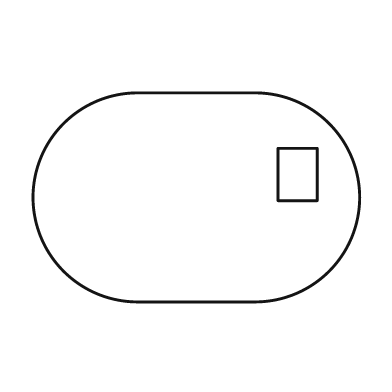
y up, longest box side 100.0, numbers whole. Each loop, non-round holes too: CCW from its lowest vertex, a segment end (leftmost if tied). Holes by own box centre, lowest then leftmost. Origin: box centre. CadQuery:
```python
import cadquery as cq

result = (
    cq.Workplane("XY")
    .moveTo(-18.0, -32.0)
    .lineTo(18.0, -32.0)
    .threePointArc((50.0, 0.0), (18.0, 32.0))
    .lineTo(-18.0, 32.0)
    .threePointArc((-50.0, 0.0), (-18.0, -32.0))
    .close()
    .moveTo(25.0, -1.0)
    .lineTo(37.0, -1.0)
    .lineTo(37.0, 15.0)
    .lineTo(25.0, 15.0)
    .close()
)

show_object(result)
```